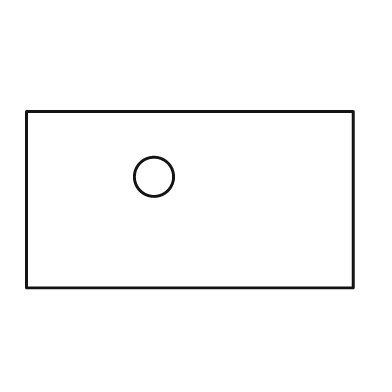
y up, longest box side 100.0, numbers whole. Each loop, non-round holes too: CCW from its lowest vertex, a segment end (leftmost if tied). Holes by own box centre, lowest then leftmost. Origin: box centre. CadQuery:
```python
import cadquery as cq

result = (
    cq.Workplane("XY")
    .moveTo(-50.0, -27.0)
    .lineTo(50.0, -27.0)
    .lineTo(50.0, 27.0)
    .lineTo(-50.0, 27.0)
    .close()
    .moveTo(-11.0, 7.0)
    .circle(6.0)
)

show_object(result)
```